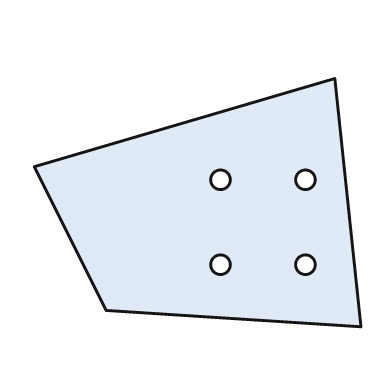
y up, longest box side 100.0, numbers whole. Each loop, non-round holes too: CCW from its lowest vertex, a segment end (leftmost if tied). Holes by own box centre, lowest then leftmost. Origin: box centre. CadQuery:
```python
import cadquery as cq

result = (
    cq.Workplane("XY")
    .moveTo(50.0, -38.0)
    .lineTo(42.0, 38.0)
    .lineTo(-50.0, 11.0)
    .lineTo(-28.0, -33.0)
    .close()
    .moveTo(7.0, -19.0)
    .circle(3.0)
    .moveTo(33.0, -19.0)
    .circle(3.0)
    .moveTo(7.0, 7.0)
    .circle(3.0)
    .moveTo(33.0, 7.0)
    .circle(3.0)
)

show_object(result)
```